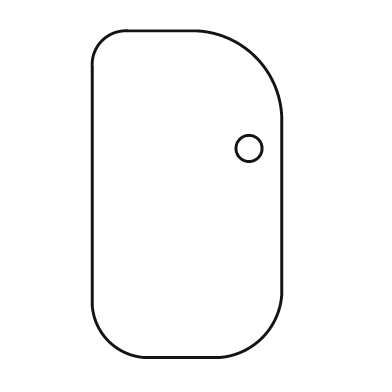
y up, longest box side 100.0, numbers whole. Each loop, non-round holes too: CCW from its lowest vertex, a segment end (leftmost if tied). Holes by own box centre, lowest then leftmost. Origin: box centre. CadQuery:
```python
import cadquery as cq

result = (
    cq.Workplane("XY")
    .moveTo(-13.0, -50.0)
    .lineTo(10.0, -50.0)
    .threePointArc((23.0, -44.0), (29.0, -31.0))
    .lineTo(29.0, 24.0)
    .threePointArc((21.0, 42.0), (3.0, 50.0))
    .lineTo(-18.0, 50.0)
    .threePointArc((-26.0, 47.0), (-29.0, 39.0))
    .lineTo(-29.0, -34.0)
    .threePointArc((-24.0, -45.0), (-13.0, -50.0))
    .close()
    .moveTo(19.0, 14.0)
    .circle(4.0)
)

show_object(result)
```